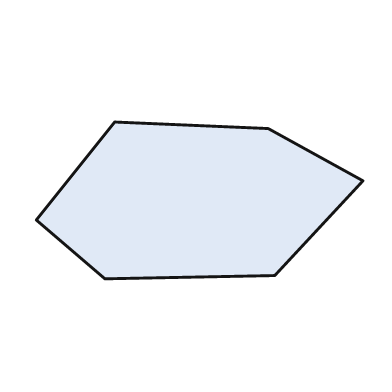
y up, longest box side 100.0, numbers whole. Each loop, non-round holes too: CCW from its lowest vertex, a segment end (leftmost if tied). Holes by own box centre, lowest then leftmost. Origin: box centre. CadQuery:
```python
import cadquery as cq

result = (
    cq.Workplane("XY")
    .moveTo(-29.0, -24.0)
    .lineTo(23.0, -23.0)
    .lineTo(50.0, 6.0)
    .lineTo(21.0, 22.0)
    .lineTo(-26.0, 24.0)
    .lineTo(-50.0, -6.0)
    .close()
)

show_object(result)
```